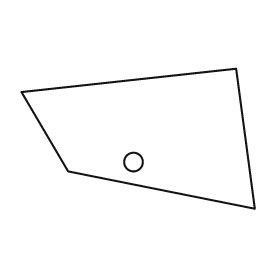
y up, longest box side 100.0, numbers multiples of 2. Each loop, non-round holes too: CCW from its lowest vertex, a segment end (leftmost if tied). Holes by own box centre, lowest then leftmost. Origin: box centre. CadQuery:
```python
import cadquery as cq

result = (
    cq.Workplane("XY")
    .moveTo(50.0, -30.0)
    .lineTo(42.0, 30.0)
    .lineTo(-50.0, 20.0)
    .lineTo(-30.0, -14.0)
    .close()
    .moveTo(-2.0, -10.0)
    .circle(4.0)
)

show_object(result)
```